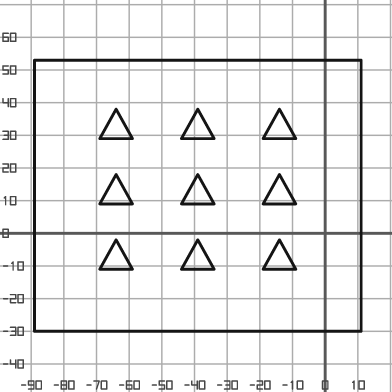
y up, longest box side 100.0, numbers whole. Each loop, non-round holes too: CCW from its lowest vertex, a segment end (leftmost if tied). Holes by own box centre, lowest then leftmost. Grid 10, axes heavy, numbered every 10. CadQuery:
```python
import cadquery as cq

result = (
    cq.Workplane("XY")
    .moveTo(-89.0, -30.0)
    .lineTo(11.0, -30.0)
    .lineTo(11.0, 53.0)
    .lineTo(-89.0, 53.0)
    .close()
    .moveTo(-69.0, -11.0)
    .lineTo(-59.0, -11.0)
    .lineTo(-64.0, -2.0)
    .close()
    .moveTo(-44.0, -11.0)
    .lineTo(-34.0, -11.0)
    .lineTo(-39.0, -2.0)
    .close()
    .moveTo(-19.0, -11.0)
    .lineTo(-9.0, -11.0)
    .lineTo(-14.0, -2.0)
    .close()
    .moveTo(-69.0, 9.0)
    .lineTo(-59.0, 9.0)
    .lineTo(-64.0, 18.0)
    .close()
    .moveTo(-44.0, 9.0)
    .lineTo(-34.0, 9.0)
    .lineTo(-39.0, 18.0)
    .close()
    .moveTo(-19.0, 9.0)
    .lineTo(-9.0, 9.0)
    .lineTo(-14.0, 18.0)
    .close()
    .moveTo(-69.0, 29.0)
    .lineTo(-59.0, 29.0)
    .lineTo(-64.0, 38.0)
    .close()
    .moveTo(-44.0, 29.0)
    .lineTo(-34.0, 29.0)
    .lineTo(-39.0, 38.0)
    .close()
    .moveTo(-19.0, 29.0)
    .lineTo(-9.0, 29.0)
    .lineTo(-14.0, 38.0)
    .close()
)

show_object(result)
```